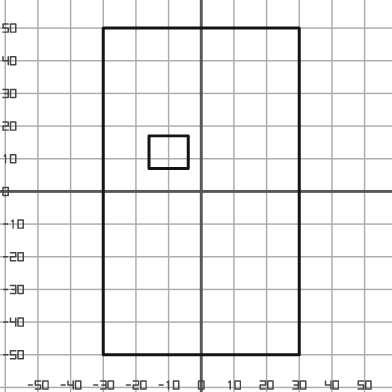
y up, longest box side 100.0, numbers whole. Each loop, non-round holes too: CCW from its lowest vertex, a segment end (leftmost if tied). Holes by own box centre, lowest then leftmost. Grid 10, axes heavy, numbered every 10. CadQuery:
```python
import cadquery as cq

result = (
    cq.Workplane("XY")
    .moveTo(-30.0, -50.0)
    .lineTo(30.0, -50.0)
    .lineTo(30.0, 50.0)
    .lineTo(-30.0, 50.0)
    .close()
    .moveTo(-16.0, 7.0)
    .lineTo(-4.0, 7.0)
    .lineTo(-4.0, 17.0)
    .lineTo(-16.0, 17.0)
    .close()
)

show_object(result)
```